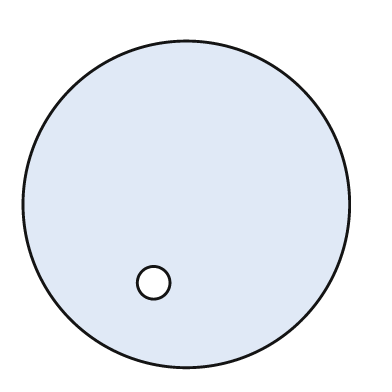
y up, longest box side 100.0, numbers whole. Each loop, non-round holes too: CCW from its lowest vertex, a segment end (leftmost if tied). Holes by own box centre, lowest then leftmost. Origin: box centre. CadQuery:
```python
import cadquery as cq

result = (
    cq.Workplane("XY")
    .moveTo(0.0, 0.0)
    .circle(50.0)
    .moveTo(-10.0, -24.0)
    .circle(5.0)
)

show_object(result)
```